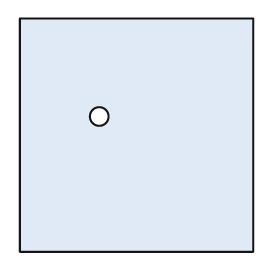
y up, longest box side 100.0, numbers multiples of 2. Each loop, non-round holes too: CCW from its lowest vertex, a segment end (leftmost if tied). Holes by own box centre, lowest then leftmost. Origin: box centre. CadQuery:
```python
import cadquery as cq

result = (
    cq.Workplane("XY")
    .moveTo(-50.0, -50.0)
    .lineTo(50.0, -50.0)
    .lineTo(50.0, 50.0)
    .lineTo(-50.0, 50.0)
    .close()
    .moveTo(-16.0, 8.0)
    .circle(4.0)
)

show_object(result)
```